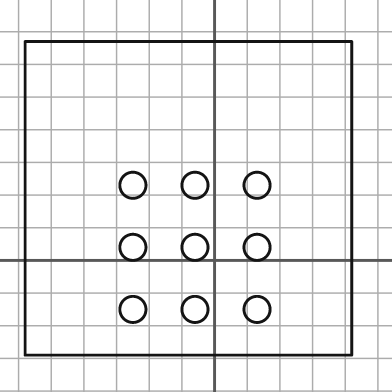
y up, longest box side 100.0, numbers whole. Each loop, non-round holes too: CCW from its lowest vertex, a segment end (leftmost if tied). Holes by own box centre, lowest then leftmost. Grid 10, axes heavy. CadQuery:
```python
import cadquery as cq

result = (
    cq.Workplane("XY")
    .moveTo(-58.0, -29.0)
    .lineTo(42.0, -29.0)
    .lineTo(42.0, 67.0)
    .lineTo(-58.0, 67.0)
    .close()
    .moveTo(-25.0, -15.0)
    .circle(4.0)
    .moveTo(-6.0, -15.0)
    .circle(4.0)
    .moveTo(13.0, -15.0)
    .circle(4.0)
    .moveTo(-25.0, 4.0)
    .circle(4.0)
    .moveTo(-6.0, 4.0)
    .circle(4.0)
    .moveTo(13.0, 4.0)
    .circle(4.0)
    .moveTo(-25.0, 23.0)
    .circle(4.0)
    .moveTo(-6.0, 23.0)
    .circle(4.0)
    .moveTo(13.0, 23.0)
    .circle(4.0)
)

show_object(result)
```